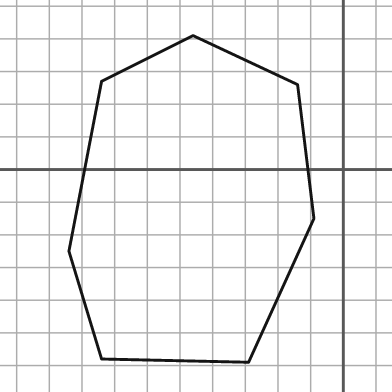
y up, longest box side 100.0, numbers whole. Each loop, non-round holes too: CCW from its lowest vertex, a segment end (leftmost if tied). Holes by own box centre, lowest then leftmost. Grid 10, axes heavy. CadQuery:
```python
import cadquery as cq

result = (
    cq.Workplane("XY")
    .moveTo(-29.0, -59.0)
    .lineTo(-9.0, -15.0)
    .lineTo(-14.0, 26.0)
    .lineTo(-46.0, 41.0)
    .lineTo(-74.0, 27.0)
    .lineTo(-84.0, -25.0)
    .lineTo(-74.0, -58.0)
    .close()
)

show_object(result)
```